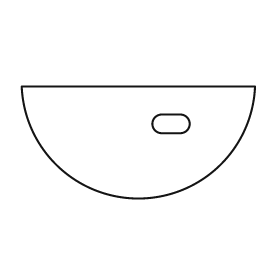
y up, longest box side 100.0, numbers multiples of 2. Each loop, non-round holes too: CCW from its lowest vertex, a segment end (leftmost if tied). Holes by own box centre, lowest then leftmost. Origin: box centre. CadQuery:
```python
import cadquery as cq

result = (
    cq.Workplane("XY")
    .moveTo(-50.0, 24.0)
    .threePointArc((0.0, -24.0), (50.0, 24.0))
    .close()
    .moveTo(10.0, 4.0)
    .lineTo(18.0, 4.0)
    .threePointArc((22.0, 8.0), (18.0, 12.0))
    .lineTo(10.0, 12.0)
    .threePointArc((6.0, 8.0), (10.0, 4.0))
    .close()
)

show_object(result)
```